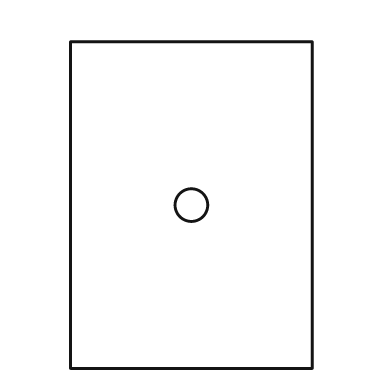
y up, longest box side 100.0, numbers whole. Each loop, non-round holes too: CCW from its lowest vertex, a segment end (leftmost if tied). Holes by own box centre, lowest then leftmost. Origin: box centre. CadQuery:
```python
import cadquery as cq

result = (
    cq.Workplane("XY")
    .moveTo(-37.0, -50.0)
    .lineTo(37.0, -50.0)
    .lineTo(37.0, 50.0)
    .lineTo(-37.0, 50.0)
    .close()
    .moveTo(0.0, 0.0)
    .circle(5.0)
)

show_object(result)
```